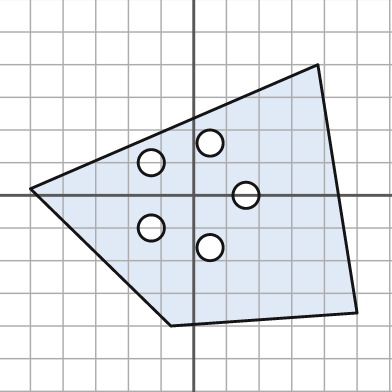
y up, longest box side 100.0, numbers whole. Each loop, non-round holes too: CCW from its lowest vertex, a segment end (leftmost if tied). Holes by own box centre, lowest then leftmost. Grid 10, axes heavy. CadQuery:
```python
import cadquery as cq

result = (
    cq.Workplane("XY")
    .moveTo(-7.0, -40.0)
    .lineTo(50.0, -36.0)
    .lineTo(38.0, 40.0)
    .lineTo(-50.0, 2.0)
    .close()
    .moveTo(5.0, -16.0)
    .circle(4.0)
    .moveTo(-13.0, -10.0)
    .circle(4.0)
    .moveTo(16.0, 0.0)
    .circle(4.0)
    .moveTo(-13.0, 10.0)
    .circle(4.0)
    .moveTo(5.0, 16.0)
    .circle(4.0)
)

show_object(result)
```